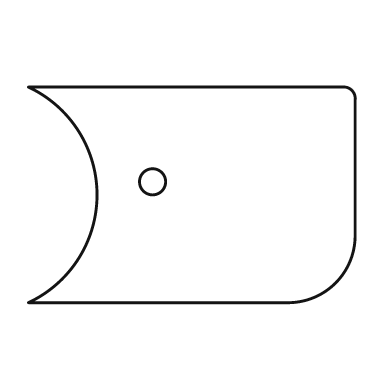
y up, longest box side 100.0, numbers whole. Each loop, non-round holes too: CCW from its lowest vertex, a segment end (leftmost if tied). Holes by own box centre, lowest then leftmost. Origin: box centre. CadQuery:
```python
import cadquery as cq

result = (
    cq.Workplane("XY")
    .moveTo(-50.0, -33.0)
    .lineTo(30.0, -33.0)
    .threePointArc((44.0, -27.0), (50.0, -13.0))
    .lineTo(50.0, 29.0)
    .threePointArc((49.0, 32.0), (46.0, 33.0))
    .lineTo(-50.0, 33.0)
    .threePointArc((-29.0, 0.0), (-50.0, -33.0))
    .close()
    .moveTo(-12.0, 4.0)
    .circle(4.0)
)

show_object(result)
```